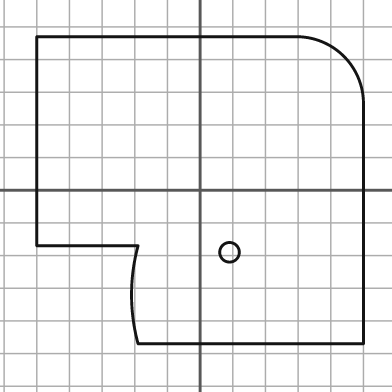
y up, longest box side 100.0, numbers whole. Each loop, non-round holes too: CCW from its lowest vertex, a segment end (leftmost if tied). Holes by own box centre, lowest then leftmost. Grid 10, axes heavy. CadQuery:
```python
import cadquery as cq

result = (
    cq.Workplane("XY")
    .moveTo(-19.0, -47.0)
    .lineTo(50.0, -47.0)
    .lineTo(50.0, 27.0)
    .threePointArc((44.0, 41.0), (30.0, 47.0))
    .lineTo(-50.0, 47.0)
    .lineTo(-50.0, -17.0)
    .lineTo(-19.0, -17.0)
    .threePointArc((-21.0, -32.0), (-19.0, -47.0))
    .close()
    .moveTo(9.0, -19.0)
    .circle(3.0)
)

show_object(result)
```